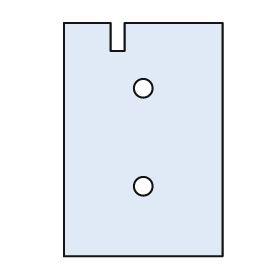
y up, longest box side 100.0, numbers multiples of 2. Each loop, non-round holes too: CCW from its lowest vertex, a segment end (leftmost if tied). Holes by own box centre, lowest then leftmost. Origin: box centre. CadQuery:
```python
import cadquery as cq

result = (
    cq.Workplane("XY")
    .moveTo(-34.0, -50.0)
    .lineTo(34.0, -50.0)
    .lineTo(34.0, 50.0)
    .lineTo(-8.0, 50.0)
    .lineTo(-8.0, 38.0)
    .lineTo(-14.0, 38.0)
    .lineTo(-14.0, 50.0)
    .lineTo(-34.0, 50.0)
    .close()
    .moveTo(0.0, -20.0)
    .circle(4.0)
    .moveTo(0.0, 22.0)
    .circle(4.0)
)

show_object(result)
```